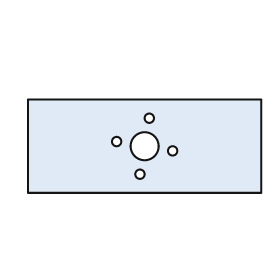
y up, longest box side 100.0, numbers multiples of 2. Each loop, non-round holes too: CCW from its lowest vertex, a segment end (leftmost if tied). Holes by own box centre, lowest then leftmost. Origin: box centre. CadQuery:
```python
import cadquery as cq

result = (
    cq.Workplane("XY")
    .moveTo(-50.0, -20.0)
    .lineTo(50.0, -20.0)
    .lineTo(50.0, 20.0)
    .lineTo(-50.0, 20.0)
    .close()
    .moveTo(-2.0, -12.0)
    .circle(2.0)
    .moveTo(12.0, -2.0)
    .circle(2.0)
    .moveTo(0.0, 0.0)
    .circle(6.0)
    .moveTo(-12.0, 2.0)
    .circle(2.0)
    .moveTo(2.0, 12.0)
    .circle(2.0)
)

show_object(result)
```